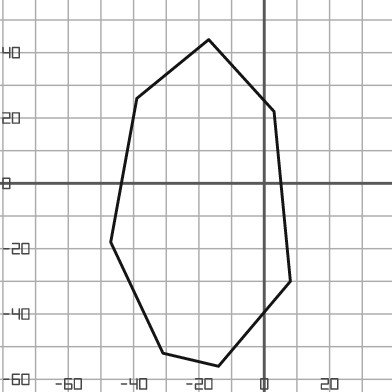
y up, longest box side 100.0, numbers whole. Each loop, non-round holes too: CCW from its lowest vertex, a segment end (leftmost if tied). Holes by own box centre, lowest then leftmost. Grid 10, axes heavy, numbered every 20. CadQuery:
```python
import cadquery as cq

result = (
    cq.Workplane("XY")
    .moveTo(-14.0, -56.0)
    .lineTo(8.0, -30.0)
    .lineTo(3.0, 22.0)
    .lineTo(-17.0, 44.0)
    .lineTo(-39.0, 26.0)
    .lineTo(-47.0, -18.0)
    .lineTo(-31.0, -52.0)
    .close()
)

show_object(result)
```